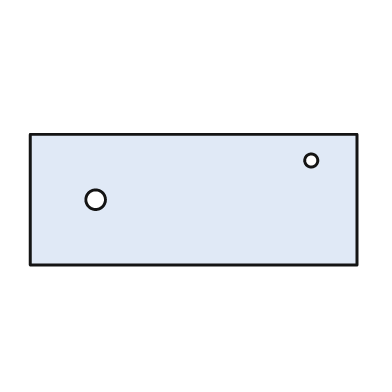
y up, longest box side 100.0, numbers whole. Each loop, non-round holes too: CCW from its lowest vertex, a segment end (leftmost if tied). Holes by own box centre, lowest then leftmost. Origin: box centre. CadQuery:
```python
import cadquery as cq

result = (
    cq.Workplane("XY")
    .moveTo(-50.0, -20.0)
    .lineTo(50.0, -20.0)
    .lineTo(50.0, 20.0)
    .lineTo(-50.0, 20.0)
    .close()
    .moveTo(-30.0, 0.0)
    .circle(3.0)
    .moveTo(36.0, 12.0)
    .circle(2.0)
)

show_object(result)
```